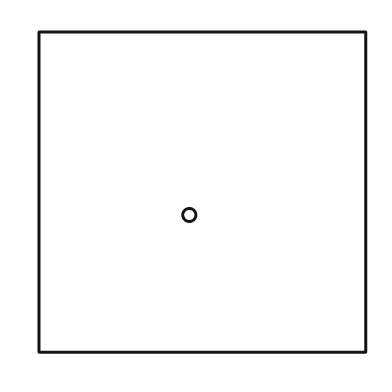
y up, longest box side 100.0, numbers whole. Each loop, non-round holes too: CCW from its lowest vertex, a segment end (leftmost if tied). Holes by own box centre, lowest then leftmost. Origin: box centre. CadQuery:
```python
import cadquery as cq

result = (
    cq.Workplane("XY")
    .moveTo(-50.0, -49.0)
    .lineTo(50.0, -49.0)
    .lineTo(50.0, 49.0)
    .lineTo(-50.0, 49.0)
    .close()
    .moveTo(-4.0, -7.0)
    .circle(2.0)
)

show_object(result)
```